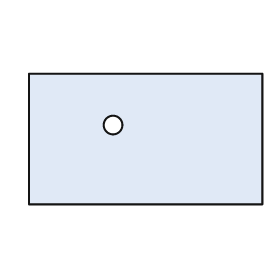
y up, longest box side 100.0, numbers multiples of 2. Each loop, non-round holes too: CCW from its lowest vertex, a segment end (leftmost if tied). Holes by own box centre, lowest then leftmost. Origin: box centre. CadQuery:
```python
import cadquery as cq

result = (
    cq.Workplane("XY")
    .moveTo(-50.0, -28.0)
    .lineTo(50.0, -28.0)
    .lineTo(50.0, 28.0)
    .lineTo(-50.0, 28.0)
    .close()
    .moveTo(-14.0, 6.0)
    .circle(4.0)
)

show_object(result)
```